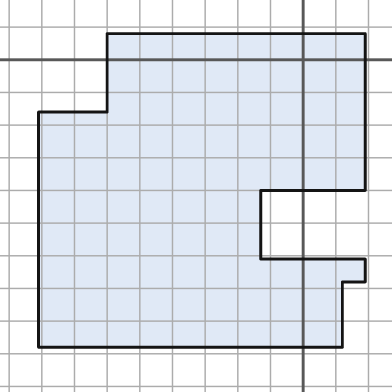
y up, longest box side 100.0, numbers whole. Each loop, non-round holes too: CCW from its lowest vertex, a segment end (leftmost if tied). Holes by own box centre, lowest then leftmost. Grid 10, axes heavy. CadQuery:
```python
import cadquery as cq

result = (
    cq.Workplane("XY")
    .moveTo(-81.0, -88.0)
    .lineTo(12.0, -88.0)
    .lineTo(12.0, -68.0)
    .lineTo(19.0, -68.0)
    .lineTo(19.0, -61.0)
    .lineTo(-13.0, -61.0)
    .lineTo(-13.0, -40.0)
    .lineTo(19.0, -40.0)
    .lineTo(19.0, 8.0)
    .lineTo(-60.0, 8.0)
    .lineTo(-60.0, -16.0)
    .lineTo(-81.0, -16.0)
    .close()
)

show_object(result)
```